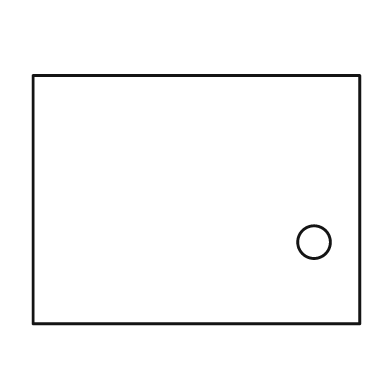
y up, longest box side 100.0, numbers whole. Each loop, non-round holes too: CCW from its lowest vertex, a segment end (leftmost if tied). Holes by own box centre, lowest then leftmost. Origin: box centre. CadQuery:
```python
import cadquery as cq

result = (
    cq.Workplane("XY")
    .moveTo(-50.0, -38.0)
    .lineTo(50.0, -38.0)
    .lineTo(50.0, 38.0)
    .lineTo(-50.0, 38.0)
    .close()
    .moveTo(36.0, -13.0)
    .circle(5.0)
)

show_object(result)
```